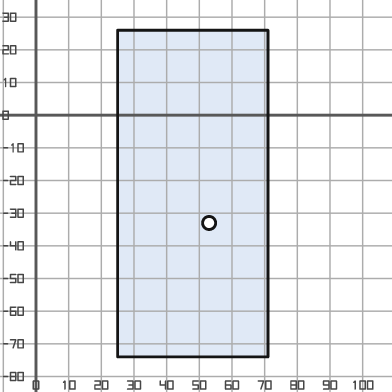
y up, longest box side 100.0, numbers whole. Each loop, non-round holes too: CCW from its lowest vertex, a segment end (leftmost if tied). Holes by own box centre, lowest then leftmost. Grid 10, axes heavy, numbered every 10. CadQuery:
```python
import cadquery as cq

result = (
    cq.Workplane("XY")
    .moveTo(25.0, -74.0)
    .lineTo(71.0, -74.0)
    .lineTo(71.0, 26.0)
    .lineTo(25.0, 26.0)
    .close()
    .moveTo(53.0, -33.0)
    .circle(2.0)
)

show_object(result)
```